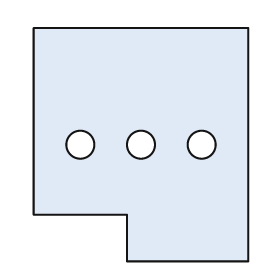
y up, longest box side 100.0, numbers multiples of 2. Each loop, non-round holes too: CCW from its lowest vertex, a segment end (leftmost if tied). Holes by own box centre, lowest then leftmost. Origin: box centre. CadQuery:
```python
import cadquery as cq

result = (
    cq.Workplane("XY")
    .moveTo(-6.0, -50.0)
    .lineTo(46.0, -50.0)
    .lineTo(46.0, 50.0)
    .lineTo(-46.0, 50.0)
    .lineTo(-46.0, -30.0)
    .lineTo(-6.0, -30.0)
    .close()
    .moveTo(-26.0, 0.0)
    .circle(6.0)
    .moveTo(0.0, 0.0)
    .circle(6.0)
    .moveTo(26.0, 0.0)
    .circle(6.0)
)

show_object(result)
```